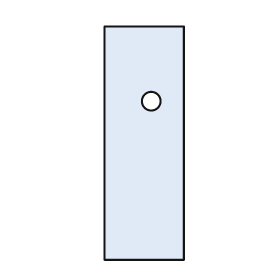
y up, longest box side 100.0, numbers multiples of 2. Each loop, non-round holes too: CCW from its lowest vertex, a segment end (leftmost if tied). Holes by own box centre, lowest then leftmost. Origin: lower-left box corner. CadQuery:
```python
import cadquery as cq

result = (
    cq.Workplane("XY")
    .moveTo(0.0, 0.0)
    .lineTo(34.0, 0.0)
    .lineTo(34.0, 100.0)
    .lineTo(0.0, 100.0)
    .close()
    .moveTo(20.0, 68.0)
    .circle(4.0)
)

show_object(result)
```